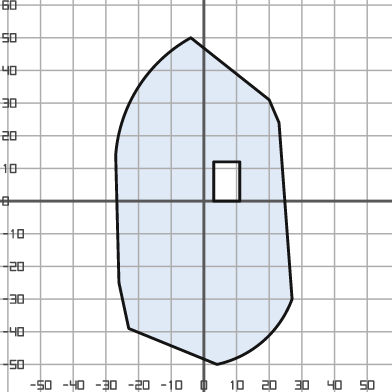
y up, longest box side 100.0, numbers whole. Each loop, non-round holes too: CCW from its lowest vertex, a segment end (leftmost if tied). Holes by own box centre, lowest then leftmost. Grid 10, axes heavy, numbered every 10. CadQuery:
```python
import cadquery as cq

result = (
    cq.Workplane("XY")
    .moveTo(4.0, -50.0)
    .threePointArc((18.0, -43.0), (27.0, -30.0))
    .lineTo(23.0, 24.0)
    .lineTo(20.0, 31.0)
    .lineTo(-4.0, 50.0)
    .threePointArc((-20.0, 35.0), (-27.0, 14.0))
    .lineTo(-26.0, -25.0)
    .lineTo(-23.0, -39.0)
    .close()
    .moveTo(3.0, 0.0)
    .lineTo(11.0, 0.0)
    .lineTo(11.0, 12.0)
    .lineTo(3.0, 12.0)
    .close()
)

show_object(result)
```